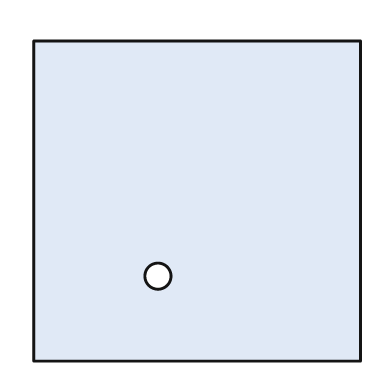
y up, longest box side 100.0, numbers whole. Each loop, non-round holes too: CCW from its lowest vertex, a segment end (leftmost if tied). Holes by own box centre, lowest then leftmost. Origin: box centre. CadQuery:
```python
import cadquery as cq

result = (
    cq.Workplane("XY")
    .moveTo(-50.0, -49.0)
    .lineTo(50.0, -49.0)
    .lineTo(50.0, 49.0)
    .lineTo(-50.0, 49.0)
    .close()
    .moveTo(-12.0, -23.0)
    .circle(4.0)
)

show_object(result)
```